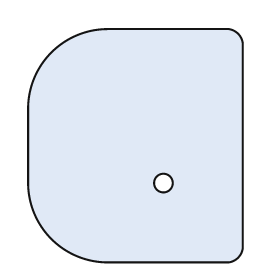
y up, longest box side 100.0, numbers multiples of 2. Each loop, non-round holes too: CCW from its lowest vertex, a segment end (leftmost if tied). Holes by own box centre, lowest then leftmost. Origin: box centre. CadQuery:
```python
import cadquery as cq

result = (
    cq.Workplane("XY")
    .moveTo(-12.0, -50.0)
    .lineTo(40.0, -50.0)
    .threePointArc((44.0, -48.0), (46.0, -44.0))
    .lineTo(46.0, 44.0)
    .threePointArc((44.0, 48.0), (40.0, 50.0))
    .lineTo(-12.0, 50.0)
    .threePointArc((-36.0, 40.0), (-46.0, 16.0))
    .lineTo(-46.0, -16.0)
    .threePointArc((-36.0, -40.0), (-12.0, -50.0))
    .close()
    .moveTo(12.0, -16.0)
    .circle(4.0)
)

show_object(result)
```